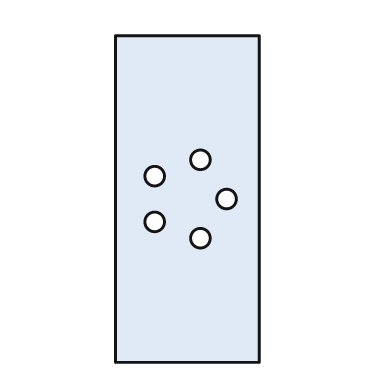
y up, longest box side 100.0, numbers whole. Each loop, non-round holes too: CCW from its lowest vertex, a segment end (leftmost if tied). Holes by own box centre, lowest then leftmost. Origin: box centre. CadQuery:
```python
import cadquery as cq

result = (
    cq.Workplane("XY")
    .moveTo(-22.0, -50.0)
    .lineTo(22.0, -50.0)
    .lineTo(22.0, 50.0)
    .lineTo(-22.0, 50.0)
    .close()
    .moveTo(4.0, -12.0)
    .circle(3.0)
    .moveTo(-10.0, -7.0)
    .circle(3.0)
    .moveTo(12.0, 0.0)
    .circle(3.0)
    .moveTo(-10.0, 7.0)
    .circle(3.0)
    .moveTo(4.0, 12.0)
    .circle(3.0)
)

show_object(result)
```